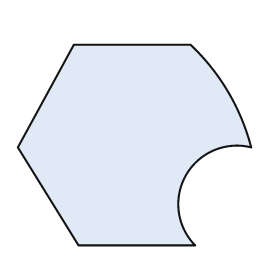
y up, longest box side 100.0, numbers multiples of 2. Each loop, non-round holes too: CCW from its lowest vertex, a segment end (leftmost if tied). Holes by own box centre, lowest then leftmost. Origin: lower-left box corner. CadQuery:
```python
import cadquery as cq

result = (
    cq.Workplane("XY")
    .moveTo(26.0, 0.0)
    .lineTo(76.0, 0.0)
    .threePointArc((72.0, 30.0), (100.0, 42.0))
    .threePointArc((90.0, 66.0), (74.0, 86.0))
    .lineTo(24.0, 86.0)
    .lineTo(0.0, 42.0)
    .close()
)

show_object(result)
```